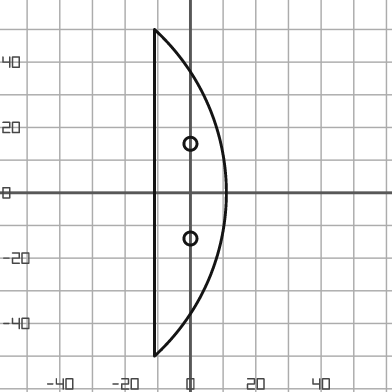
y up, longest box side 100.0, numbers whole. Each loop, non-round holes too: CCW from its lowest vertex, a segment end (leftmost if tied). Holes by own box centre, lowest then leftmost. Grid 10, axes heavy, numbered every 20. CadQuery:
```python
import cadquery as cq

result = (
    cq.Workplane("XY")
    .moveTo(-11.0, -50.0)
    .threePointArc((11.0, 0.0), (-11.0, 50.0))
    .close()
    .moveTo(0.0, -14.0)
    .circle(2.0)
    .moveTo(0.0, 15.0)
    .circle(2.0)
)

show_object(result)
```